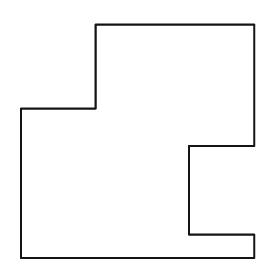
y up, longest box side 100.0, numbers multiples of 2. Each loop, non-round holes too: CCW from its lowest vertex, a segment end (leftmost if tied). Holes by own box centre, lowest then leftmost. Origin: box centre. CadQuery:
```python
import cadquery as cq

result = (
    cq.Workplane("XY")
    .moveTo(-50.0, -50.0)
    .lineTo(50.0, -50.0)
    .lineTo(50.0, -40.0)
    .lineTo(22.0, -40.0)
    .lineTo(22.0, -2.0)
    .lineTo(50.0, -2.0)
    .lineTo(50.0, 50.0)
    .lineTo(-18.0, 50.0)
    .lineTo(-18.0, 14.0)
    .lineTo(-50.0, 14.0)
    .close()
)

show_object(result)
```